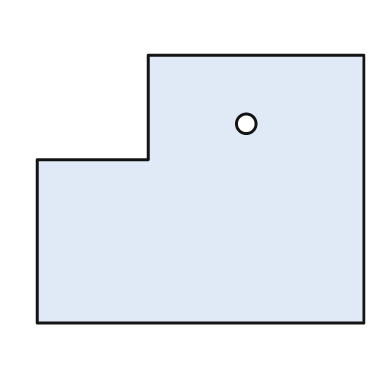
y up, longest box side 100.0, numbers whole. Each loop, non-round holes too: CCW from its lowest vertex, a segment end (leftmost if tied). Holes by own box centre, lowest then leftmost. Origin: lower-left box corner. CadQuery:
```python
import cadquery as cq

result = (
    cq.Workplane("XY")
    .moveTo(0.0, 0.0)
    .lineTo(100.0, 0.0)
    .lineTo(100.0, 82.0)
    .lineTo(34.0, 82.0)
    .lineTo(34.0, 50.0)
    .lineTo(0.0, 50.0)
    .close()
    .moveTo(64.0, 61.0)
    .circle(3.0)
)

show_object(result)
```